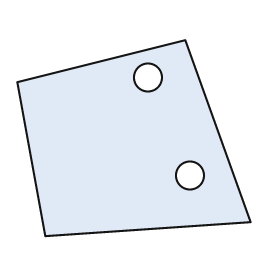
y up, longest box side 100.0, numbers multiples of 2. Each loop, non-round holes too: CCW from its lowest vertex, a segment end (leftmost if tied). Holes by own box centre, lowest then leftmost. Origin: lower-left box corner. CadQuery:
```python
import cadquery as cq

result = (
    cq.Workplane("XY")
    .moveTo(12.0, 0.0)
    .lineTo(100.0, 6.0)
    .lineTo(72.0, 84.0)
    .lineTo(0.0, 66.0)
    .close()
    .moveTo(74.0, 26.0)
    .circle(6.0)
    .moveTo(56.0, 68.0)
    .circle(6.0)
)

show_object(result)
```